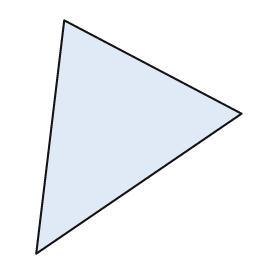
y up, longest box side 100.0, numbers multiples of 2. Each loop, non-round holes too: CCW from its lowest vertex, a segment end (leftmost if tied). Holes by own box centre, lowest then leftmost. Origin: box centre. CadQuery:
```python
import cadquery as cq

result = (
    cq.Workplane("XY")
    .moveTo(-44.0, -50.0)
    .lineTo(44.0, 10.0)
    .lineTo(-32.0, 50.0)
    .close()
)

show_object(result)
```